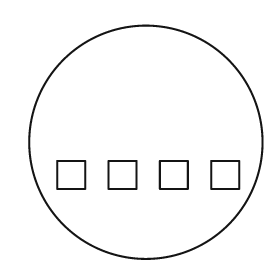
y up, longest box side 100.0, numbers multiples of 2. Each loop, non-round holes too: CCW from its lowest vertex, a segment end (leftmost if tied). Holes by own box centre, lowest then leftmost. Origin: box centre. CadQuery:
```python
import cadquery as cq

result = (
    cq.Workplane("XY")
    .moveTo(0.0, 0.0)
    .circle(50.0)
    .moveTo(-38.0, -20.0)
    .lineTo(-26.0, -20.0)
    .lineTo(-26.0, -8.0)
    .lineTo(-38.0, -8.0)
    .close()
    .moveTo(-16.0, -20.0)
    .lineTo(-4.0, -20.0)
    .lineTo(-4.0, -8.0)
    .lineTo(-16.0, -8.0)
    .close()
    .moveTo(6.0, -20.0)
    .lineTo(18.0, -20.0)
    .lineTo(18.0, -8.0)
    .lineTo(6.0, -8.0)
    .close()
    .moveTo(28.0, -20.0)
    .lineTo(40.0, -20.0)
    .lineTo(40.0, -8.0)
    .lineTo(28.0, -8.0)
    .close()
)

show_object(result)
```